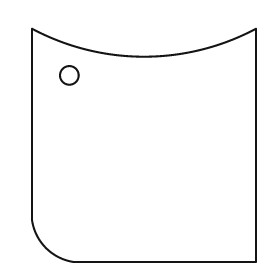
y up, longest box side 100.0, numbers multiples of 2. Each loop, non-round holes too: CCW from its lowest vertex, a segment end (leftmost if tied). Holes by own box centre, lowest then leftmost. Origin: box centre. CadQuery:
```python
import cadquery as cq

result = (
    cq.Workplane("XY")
    .moveTo(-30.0, -50.0)
    .lineTo(48.0, -50.0)
    .lineTo(48.0, 50.0)
    .threePointArc((0.0, 38.0), (-48.0, 50.0))
    .lineTo(-48.0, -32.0)
    .threePointArc((-42.0, -44.0), (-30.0, -50.0))
    .close()
    .moveTo(-32.0, 30.0)
    .circle(4.0)
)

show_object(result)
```